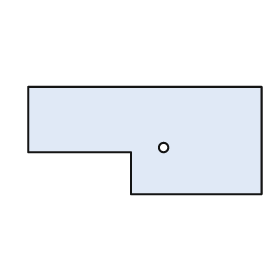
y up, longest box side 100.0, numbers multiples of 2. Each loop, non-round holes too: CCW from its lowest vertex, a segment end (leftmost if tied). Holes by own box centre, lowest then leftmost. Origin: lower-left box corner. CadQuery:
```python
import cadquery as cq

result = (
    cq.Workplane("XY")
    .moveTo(44.0, 0.0)
    .lineTo(100.0, 0.0)
    .lineTo(100.0, 46.0)
    .lineTo(0.0, 46.0)
    .lineTo(0.0, 18.0)
    .lineTo(44.0, 18.0)
    .close()
    .moveTo(58.0, 20.0)
    .circle(2.0)
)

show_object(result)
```